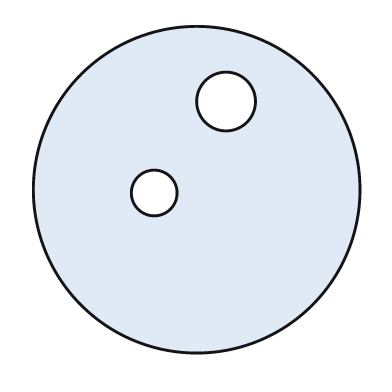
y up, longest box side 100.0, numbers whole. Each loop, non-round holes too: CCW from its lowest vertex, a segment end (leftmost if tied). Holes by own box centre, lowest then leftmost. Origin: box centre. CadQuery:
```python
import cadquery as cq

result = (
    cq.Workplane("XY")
    .moveTo(0.0, 0.0)
    .circle(50.0)
    .moveTo(-13.0, -1.0)
    .circle(7.0)
    .moveTo(9.0, 27.0)
    .circle(9.0)
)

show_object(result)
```